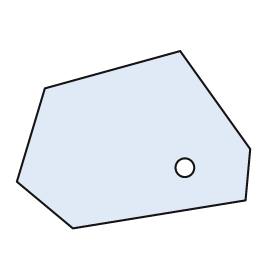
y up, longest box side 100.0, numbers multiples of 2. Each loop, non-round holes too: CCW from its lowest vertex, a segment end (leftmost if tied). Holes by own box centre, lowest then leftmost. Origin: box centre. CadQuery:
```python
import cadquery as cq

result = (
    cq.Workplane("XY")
    .moveTo(-26.0, -38.0)
    .lineTo(48.0, -26.0)
    .lineTo(50.0, -4.0)
    .lineTo(20.0, 38.0)
    .lineTo(-38.0, 22.0)
    .lineTo(-50.0, -18.0)
    .close()
    .moveTo(22.0, -12.0)
    .circle(4.0)
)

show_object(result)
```